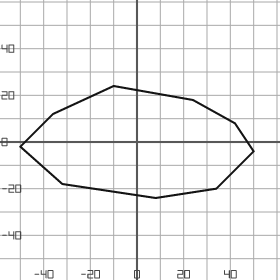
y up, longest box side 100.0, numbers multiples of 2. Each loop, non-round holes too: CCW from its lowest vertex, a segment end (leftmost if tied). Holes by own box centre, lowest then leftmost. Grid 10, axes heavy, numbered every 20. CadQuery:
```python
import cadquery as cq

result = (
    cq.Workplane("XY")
    .moveTo(8.0, -24.0)
    .lineTo(34.0, -20.0)
    .lineTo(50.0, -4.0)
    .lineTo(42.0, 8.0)
    .lineTo(24.0, 18.0)
    .lineTo(-10.0, 24.0)
    .lineTo(-36.0, 12.0)
    .lineTo(-50.0, -2.0)
    .lineTo(-32.0, -18.0)
    .close()
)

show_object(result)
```